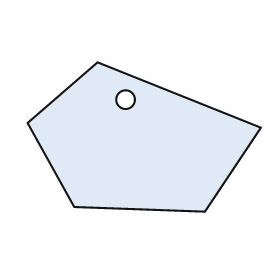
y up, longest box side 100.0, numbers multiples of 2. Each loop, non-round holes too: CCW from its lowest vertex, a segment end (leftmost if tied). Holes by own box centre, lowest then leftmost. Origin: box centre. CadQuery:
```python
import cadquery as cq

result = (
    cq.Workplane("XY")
    .moveTo(26.0, -32.0)
    .lineTo(50.0, 4.0)
    .lineTo(-20.0, 32.0)
    .lineTo(-50.0, 6.0)
    .lineTo(-30.0, -30.0)
    .close()
    .moveTo(-8.0, 16.0)
    .circle(4.0)
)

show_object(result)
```